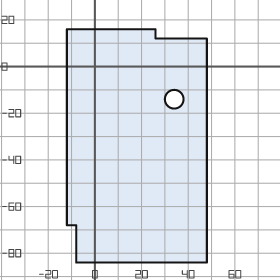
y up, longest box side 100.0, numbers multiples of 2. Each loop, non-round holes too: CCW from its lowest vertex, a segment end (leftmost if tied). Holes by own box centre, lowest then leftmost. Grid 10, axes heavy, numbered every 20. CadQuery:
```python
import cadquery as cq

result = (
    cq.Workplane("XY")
    .moveTo(-8.0, -84.0)
    .lineTo(48.0, -84.0)
    .lineTo(48.0, 12.0)
    .lineTo(26.0, 12.0)
    .lineTo(26.0, 16.0)
    .lineTo(-12.0, 16.0)
    .lineTo(-12.0, -68.0)
    .lineTo(-8.0, -68.0)
    .close()
    .moveTo(34.0, -14.0)
    .circle(4.0)
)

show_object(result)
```